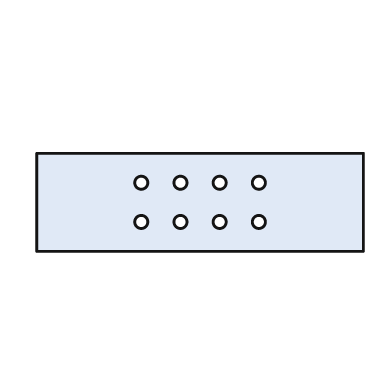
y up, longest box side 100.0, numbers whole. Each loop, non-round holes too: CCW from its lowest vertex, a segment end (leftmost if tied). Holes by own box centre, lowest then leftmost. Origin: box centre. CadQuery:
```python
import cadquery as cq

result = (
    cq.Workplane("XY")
    .moveTo(-50.0, -15.0)
    .lineTo(50.0, -15.0)
    .lineTo(50.0, 15.0)
    .lineTo(-50.0, 15.0)
    .close()
    .moveTo(-18.0, -6.0)
    .circle(2.0)
    .moveTo(-6.0, -6.0)
    .circle(2.0)
    .moveTo(6.0, -6.0)
    .circle(2.0)
    .moveTo(18.0, -6.0)
    .circle(2.0)
    .moveTo(-18.0, 6.0)
    .circle(2.0)
    .moveTo(-6.0, 6.0)
    .circle(2.0)
    .moveTo(6.0, 6.0)
    .circle(2.0)
    .moveTo(18.0, 6.0)
    .circle(2.0)
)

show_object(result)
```